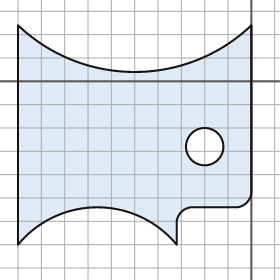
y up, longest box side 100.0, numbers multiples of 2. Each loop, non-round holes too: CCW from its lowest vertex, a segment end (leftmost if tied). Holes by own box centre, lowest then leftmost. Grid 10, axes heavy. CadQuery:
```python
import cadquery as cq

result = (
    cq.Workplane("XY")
    .moveTo(-100.0, -70.0)
    .threePointArc((-66.0, -54.0), (-32.0, -70.0))
    .lineTo(-32.0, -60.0)
    .threePointArc((-30.0, -56.0), (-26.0, -54.0))
    .lineTo(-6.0, -54.0)
    .threePointArc((-2.0, -52.0), (0.0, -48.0))
    .lineTo(0.0, 24.0)
    .threePointArc((-50.0, 4.0), (-100.0, 24.0))
    .close()
    .moveTo(-20.0, -28.0)
    .circle(8.0)
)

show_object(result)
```